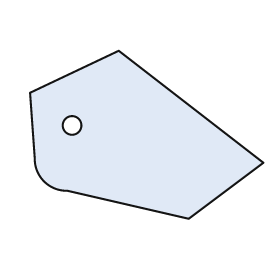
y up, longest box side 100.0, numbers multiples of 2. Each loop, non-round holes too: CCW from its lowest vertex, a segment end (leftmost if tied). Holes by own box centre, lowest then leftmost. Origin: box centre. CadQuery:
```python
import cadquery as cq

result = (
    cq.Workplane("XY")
    .moveTo(18.0, -36.0)
    .lineTo(50.0, -12.0)
    .lineTo(-12.0, 36.0)
    .lineTo(-50.0, 18.0)
    .lineTo(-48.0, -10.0)
    .threePointArc((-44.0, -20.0), (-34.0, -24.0))
    .close()
    .moveTo(-32.0, 4.0)
    .circle(4.0)
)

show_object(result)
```